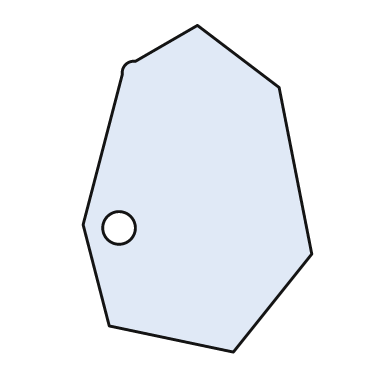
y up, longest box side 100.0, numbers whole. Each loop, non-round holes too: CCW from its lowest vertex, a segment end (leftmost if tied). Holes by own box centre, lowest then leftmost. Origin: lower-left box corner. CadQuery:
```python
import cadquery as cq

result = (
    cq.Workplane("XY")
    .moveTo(46.0, 0.0)
    .lineTo(70.0, 30.0)
    .lineTo(60.0, 81.0)
    .lineTo(35.0, 100.0)
    .lineTo(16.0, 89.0)
    .threePointArc((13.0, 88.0), (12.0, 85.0))
    .lineTo(0.0, 39.0)
    .lineTo(8.0, 8.0)
    .close()
    .moveTo(11.0, 38.0)
    .circle(5.0)
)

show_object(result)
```